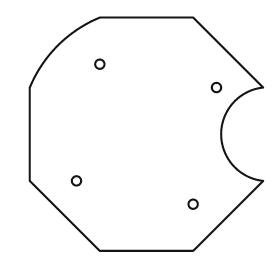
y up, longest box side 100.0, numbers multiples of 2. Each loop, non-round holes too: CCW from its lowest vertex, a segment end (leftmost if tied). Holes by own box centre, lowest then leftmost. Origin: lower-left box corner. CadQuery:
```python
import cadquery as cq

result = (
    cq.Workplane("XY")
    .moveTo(30.0, 0.0)
    .lineTo(70.0, 0.0)
    .lineTo(100.0, 30.0)
    .threePointArc((82.0, 50.0), (100.0, 70.0))
    .lineTo(70.0, 100.0)
    .lineTo(30.0, 100.0)
    .threePointArc((12.0, 88.0), (0.0, 70.0))
    .lineTo(0.0, 30.0)
    .close()
    .moveTo(70.0, 20.0)
    .circle(2.0)
    .moveTo(20.0, 30.0)
    .circle(2.0)
    .moveTo(80.0, 70.0)
    .circle(2.0)
    .moveTo(30.0, 80.0)
    .circle(2.0)
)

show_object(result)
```